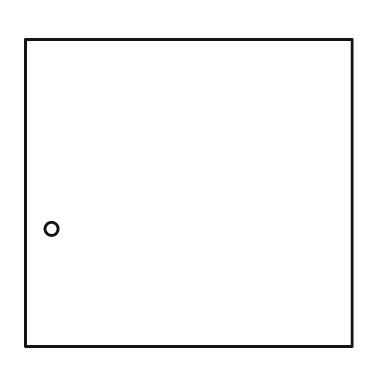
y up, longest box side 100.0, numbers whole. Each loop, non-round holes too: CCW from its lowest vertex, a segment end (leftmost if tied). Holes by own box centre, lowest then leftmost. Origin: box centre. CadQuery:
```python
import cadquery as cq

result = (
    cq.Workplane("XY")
    .moveTo(-50.0, -47.0)
    .lineTo(50.0, -47.0)
    .lineTo(50.0, 47.0)
    .lineTo(-50.0, 47.0)
    .close()
    .moveTo(-42.0, -11.0)
    .circle(2.0)
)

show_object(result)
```